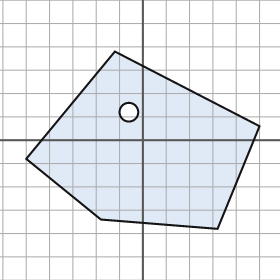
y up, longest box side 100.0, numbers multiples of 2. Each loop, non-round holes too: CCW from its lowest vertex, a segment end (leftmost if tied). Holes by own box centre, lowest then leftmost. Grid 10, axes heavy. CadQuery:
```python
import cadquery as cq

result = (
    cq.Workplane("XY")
    .moveTo(32.0, -38.0)
    .lineTo(50.0, 6.0)
    .lineTo(-12.0, 38.0)
    .lineTo(-50.0, -8.0)
    .lineTo(-18.0, -34.0)
    .close()
    .moveTo(-6.0, 12.0)
    .circle(4.0)
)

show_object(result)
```